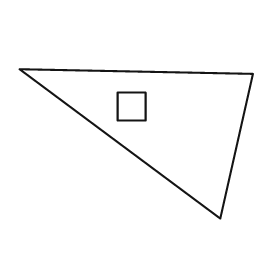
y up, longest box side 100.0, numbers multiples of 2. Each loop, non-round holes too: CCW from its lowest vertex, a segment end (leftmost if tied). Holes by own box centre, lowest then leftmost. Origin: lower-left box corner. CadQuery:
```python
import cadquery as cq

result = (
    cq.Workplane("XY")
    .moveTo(86.0, 0.0)
    .lineTo(100.0, 62.0)
    .lineTo(0.0, 64.0)
    .close()
    .moveTo(42.0, 42.0)
    .lineTo(54.0, 42.0)
    .lineTo(54.0, 54.0)
    .lineTo(42.0, 54.0)
    .close()
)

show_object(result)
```